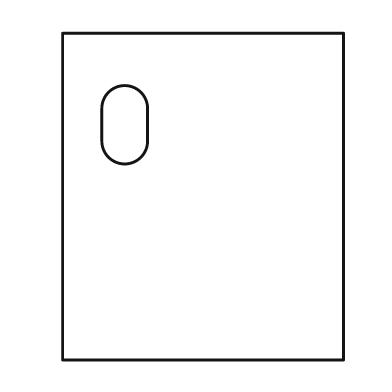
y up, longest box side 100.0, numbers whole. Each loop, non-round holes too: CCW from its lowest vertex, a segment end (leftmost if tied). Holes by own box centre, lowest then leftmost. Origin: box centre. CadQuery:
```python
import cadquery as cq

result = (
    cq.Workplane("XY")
    .moveTo(-43.0, -50.0)
    .lineTo(43.0, -50.0)
    .lineTo(43.0, 50.0)
    .lineTo(-43.0, 50.0)
    .close()
    .moveTo(-31.0, 17.0)
    .threePointArc((-24.0, 10.0), (-17.0, 17.0))
    .lineTo(-17.0, 27.0)
    .threePointArc((-24.0, 34.0), (-31.0, 27.0))
    .close()
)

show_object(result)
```